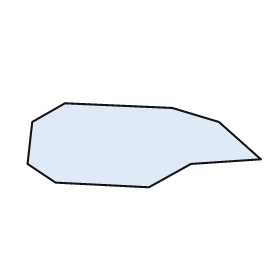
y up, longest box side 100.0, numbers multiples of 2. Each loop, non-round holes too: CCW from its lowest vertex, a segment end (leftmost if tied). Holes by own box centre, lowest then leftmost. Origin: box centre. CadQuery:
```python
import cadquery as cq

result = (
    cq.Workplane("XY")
    .moveTo(2.0, -18.0)
    .lineTo(20.0, -8.0)
    .lineTo(50.0, -6.0)
    .lineTo(32.0, 10.0)
    .lineTo(12.0, 16.0)
    .lineTo(-34.0, 18.0)
    .lineTo(-48.0, 10.0)
    .lineTo(-50.0, -8.0)
    .lineTo(-38.0, -16.0)
    .close()
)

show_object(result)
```